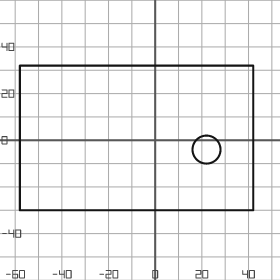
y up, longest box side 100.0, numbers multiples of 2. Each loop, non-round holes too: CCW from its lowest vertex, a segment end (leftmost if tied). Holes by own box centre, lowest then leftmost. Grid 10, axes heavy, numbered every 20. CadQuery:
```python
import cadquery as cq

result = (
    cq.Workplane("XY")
    .moveTo(-58.0, -30.0)
    .lineTo(42.0, -30.0)
    .lineTo(42.0, 32.0)
    .lineTo(-58.0, 32.0)
    .close()
    .moveTo(22.0, -4.0)
    .circle(6.0)
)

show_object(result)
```